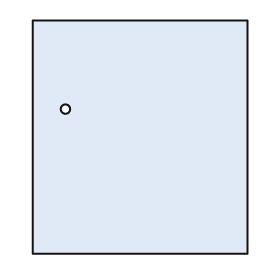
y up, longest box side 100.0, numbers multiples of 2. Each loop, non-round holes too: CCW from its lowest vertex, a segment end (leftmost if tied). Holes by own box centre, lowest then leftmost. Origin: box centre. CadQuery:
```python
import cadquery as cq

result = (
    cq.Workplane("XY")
    .moveTo(-46.0, -50.0)
    .lineTo(46.0, -50.0)
    .lineTo(46.0, 50.0)
    .lineTo(-46.0, 50.0)
    .close()
    .moveTo(-32.0, 12.0)
    .circle(2.0)
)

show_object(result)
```